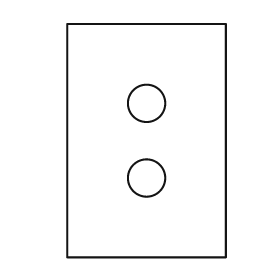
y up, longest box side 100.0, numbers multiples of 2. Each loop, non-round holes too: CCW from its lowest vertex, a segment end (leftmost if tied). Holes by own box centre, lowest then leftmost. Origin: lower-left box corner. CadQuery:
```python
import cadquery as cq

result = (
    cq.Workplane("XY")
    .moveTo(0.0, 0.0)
    .lineTo(68.0, 0.0)
    .lineTo(68.0, 100.0)
    .lineTo(0.0, 100.0)
    .close()
    .moveTo(34.0, 34.0)
    .circle(8.0)
    .moveTo(34.0, 66.0)
    .circle(8.0)
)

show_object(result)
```